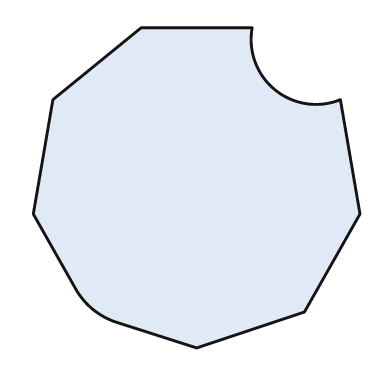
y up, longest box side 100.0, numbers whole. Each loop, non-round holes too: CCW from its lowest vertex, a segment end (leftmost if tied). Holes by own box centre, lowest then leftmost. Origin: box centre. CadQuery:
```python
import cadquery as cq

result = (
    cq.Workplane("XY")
    .moveTo(0.0, -49.0)
    .lineTo(33.0, -38.0)
    .lineTo(50.0, -8.0)
    .lineTo(44.0, 27.0)
    .threePointArc((24.0, 30.0), (17.0, 49.0))
    .lineTo(-17.0, 49.0)
    .lineTo(-44.0, 27.0)
    .lineTo(-50.0, -8.0)
    .lineTo(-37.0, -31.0)
    .threePointArc((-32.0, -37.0), (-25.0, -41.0))
    .close()
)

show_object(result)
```